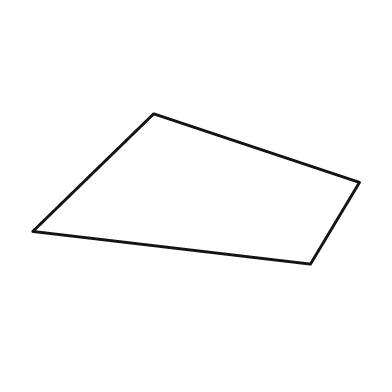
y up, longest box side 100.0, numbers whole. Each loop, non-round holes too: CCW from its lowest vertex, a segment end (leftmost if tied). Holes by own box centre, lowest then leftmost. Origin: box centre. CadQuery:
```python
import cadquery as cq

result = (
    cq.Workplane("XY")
    .moveTo(35.0, -23.0)
    .lineTo(50.0, 2.0)
    .lineTo(-13.0, 23.0)
    .lineTo(-50.0, -13.0)
    .close()
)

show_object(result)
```